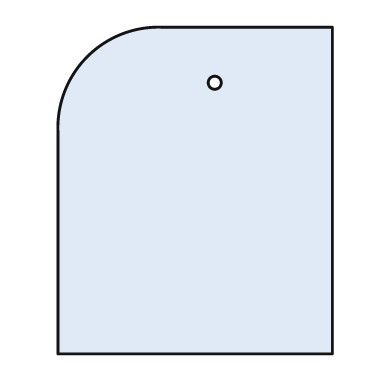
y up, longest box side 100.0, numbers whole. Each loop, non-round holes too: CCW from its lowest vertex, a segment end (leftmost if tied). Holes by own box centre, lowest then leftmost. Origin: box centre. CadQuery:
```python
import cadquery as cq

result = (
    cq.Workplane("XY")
    .moveTo(-42.0, -50.0)
    .lineTo(42.0, -50.0)
    .lineTo(42.0, 50.0)
    .lineTo(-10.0, 50.0)
    .threePointArc((-33.0, 41.0), (-42.0, 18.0))
    .close()
    .moveTo(6.0, 33.0)
    .circle(2.0)
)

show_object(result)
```